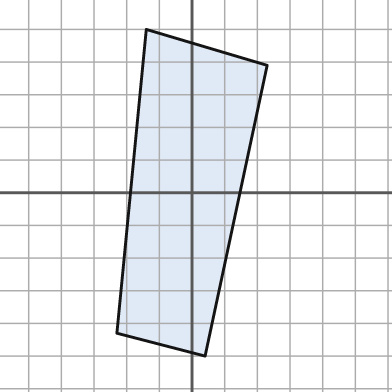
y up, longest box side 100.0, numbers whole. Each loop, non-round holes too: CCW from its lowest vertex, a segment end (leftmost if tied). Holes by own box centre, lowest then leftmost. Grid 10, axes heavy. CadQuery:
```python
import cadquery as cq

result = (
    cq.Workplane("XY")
    .moveTo(4.0, -50.0)
    .lineTo(23.0, 39.0)
    .lineTo(-14.0, 50.0)
    .lineTo(-23.0, -43.0)
    .close()
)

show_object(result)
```